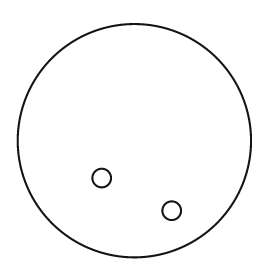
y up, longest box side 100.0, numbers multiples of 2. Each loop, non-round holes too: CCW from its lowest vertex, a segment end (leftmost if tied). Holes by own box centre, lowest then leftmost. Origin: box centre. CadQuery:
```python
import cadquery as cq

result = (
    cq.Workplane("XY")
    .moveTo(0.0, 0.0)
    .circle(50.0)
    .moveTo(16.0, -30.0)
    .circle(4.0)
    .moveTo(-14.0, -16.0)
    .circle(4.0)
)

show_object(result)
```